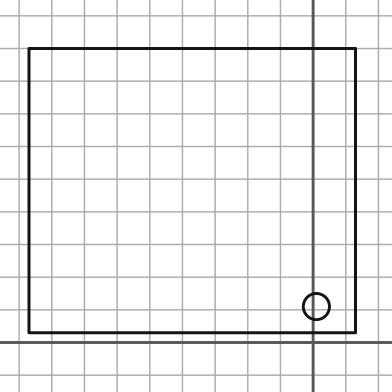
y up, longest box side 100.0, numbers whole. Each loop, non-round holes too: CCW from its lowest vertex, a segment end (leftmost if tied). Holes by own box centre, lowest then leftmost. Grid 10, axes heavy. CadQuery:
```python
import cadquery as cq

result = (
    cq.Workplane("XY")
    .moveTo(-87.0, 3.0)
    .lineTo(13.0, 3.0)
    .lineTo(13.0, 90.0)
    .lineTo(-87.0, 90.0)
    .close()
    .moveTo(1.0, 11.0)
    .circle(4.0)
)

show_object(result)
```